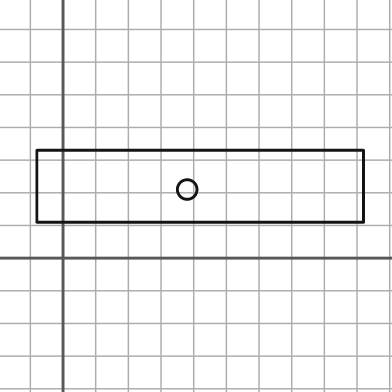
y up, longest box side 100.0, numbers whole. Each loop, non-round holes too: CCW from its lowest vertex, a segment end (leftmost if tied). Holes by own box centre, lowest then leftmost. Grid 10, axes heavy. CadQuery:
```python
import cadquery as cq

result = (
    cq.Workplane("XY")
    .moveTo(-8.0, 11.0)
    .lineTo(92.0, 11.0)
    .lineTo(92.0, 33.0)
    .lineTo(-8.0, 33.0)
    .close()
    .moveTo(38.0, 21.0)
    .circle(3.0)
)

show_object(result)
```